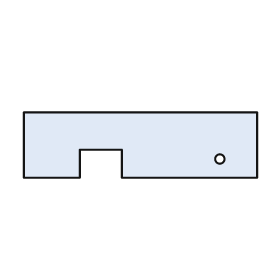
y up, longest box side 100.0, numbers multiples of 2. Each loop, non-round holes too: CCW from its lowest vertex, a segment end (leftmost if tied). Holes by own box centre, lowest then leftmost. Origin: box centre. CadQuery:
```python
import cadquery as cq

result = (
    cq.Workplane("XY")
    .moveTo(-50.0, -14.0)
    .lineTo(-26.0, -14.0)
    .lineTo(-26.0, -2.0)
    .lineTo(-8.0, -2.0)
    .lineTo(-8.0, -14.0)
    .lineTo(50.0, -14.0)
    .lineTo(50.0, 14.0)
    .lineTo(-50.0, 14.0)
    .close()
    .moveTo(34.0, -6.0)
    .circle(2.0)
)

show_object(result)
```